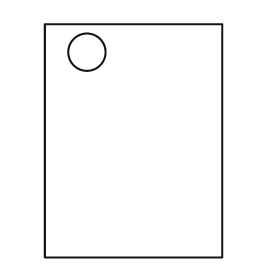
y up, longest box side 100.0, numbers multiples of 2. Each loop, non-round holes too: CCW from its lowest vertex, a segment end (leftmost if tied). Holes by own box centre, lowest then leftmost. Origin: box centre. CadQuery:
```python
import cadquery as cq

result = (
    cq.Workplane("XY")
    .moveTo(-38.0, -50.0)
    .lineTo(38.0, -50.0)
    .lineTo(38.0, 50.0)
    .lineTo(-38.0, 50.0)
    .close()
    .moveTo(-20.0, 38.0)
    .circle(8.0)
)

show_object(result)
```